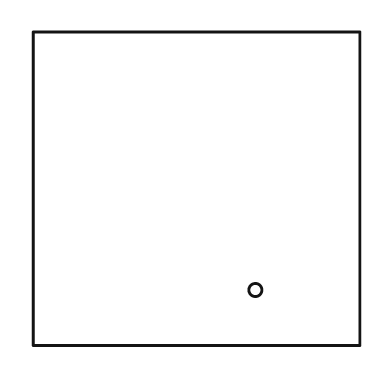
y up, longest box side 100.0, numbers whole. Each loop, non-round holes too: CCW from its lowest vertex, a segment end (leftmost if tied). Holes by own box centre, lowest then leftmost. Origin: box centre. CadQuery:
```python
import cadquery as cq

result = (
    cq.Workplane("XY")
    .moveTo(-50.0, -48.0)
    .lineTo(50.0, -48.0)
    .lineTo(50.0, 48.0)
    .lineTo(-50.0, 48.0)
    .close()
    .moveTo(18.0, -31.0)
    .circle(2.0)
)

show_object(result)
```